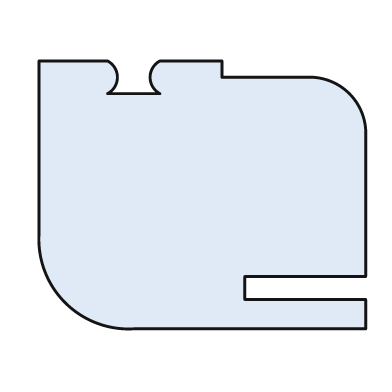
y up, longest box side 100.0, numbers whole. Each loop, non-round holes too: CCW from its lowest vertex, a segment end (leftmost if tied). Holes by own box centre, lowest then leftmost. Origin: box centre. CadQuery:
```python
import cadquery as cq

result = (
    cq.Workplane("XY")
    .moveTo(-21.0, -41.0)
    .lineTo(50.0, -41.0)
    .lineTo(50.0, -32.0)
    .lineTo(13.0, -32.0)
    .lineTo(13.0, -25.0)
    .lineTo(50.0, -25.0)
    .lineTo(50.0, 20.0)
    .threePointArc((45.0, 31.0), (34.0, 36.0))
    .lineTo(6.0, 36.0)
    .lineTo(6.0, 41.0)
    .lineTo(-13.0, 41.0)
    .threePointArc((-16.0, 36.0), (-13.0, 31.0))
    .lineTo(-29.0, 31.0)
    .threePointArc((-26.0, 36.0), (-29.0, 41.0))
    .lineTo(-50.0, 41.0)
    .lineTo(-50.0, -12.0)
    .threePointArc((-42.0, -33.0), (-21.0, -41.0))
    .close()
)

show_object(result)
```